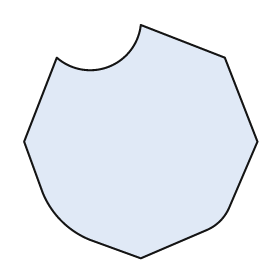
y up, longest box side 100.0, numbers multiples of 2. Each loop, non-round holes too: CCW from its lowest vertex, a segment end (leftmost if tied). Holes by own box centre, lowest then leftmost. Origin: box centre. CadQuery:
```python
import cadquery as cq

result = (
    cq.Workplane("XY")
    .moveTo(0.0, -50.0)
    .lineTo(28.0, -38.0)
    .threePointArc((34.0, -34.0), (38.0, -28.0))
    .lineTo(50.0, 0.0)
    .lineTo(36.0, 36.0)
    .lineTo(0.0, 50.0)
    .threePointArc((-14.0, 32.0), (-36.0, 36.0))
    .lineTo(-50.0, 0.0)
    .lineTo(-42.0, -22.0)
    .threePointArc((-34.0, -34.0), (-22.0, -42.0))
    .close()
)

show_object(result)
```